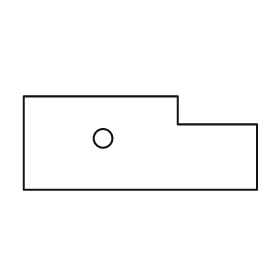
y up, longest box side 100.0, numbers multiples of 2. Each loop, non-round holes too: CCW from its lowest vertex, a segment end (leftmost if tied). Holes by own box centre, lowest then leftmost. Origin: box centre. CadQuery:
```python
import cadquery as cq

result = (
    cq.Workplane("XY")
    .moveTo(-50.0, -20.0)
    .lineTo(50.0, -20.0)
    .lineTo(50.0, 8.0)
    .lineTo(16.0, 8.0)
    .lineTo(16.0, 20.0)
    .lineTo(-50.0, 20.0)
    .close()
    .moveTo(-16.0, 2.0)
    .circle(4.0)
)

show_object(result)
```